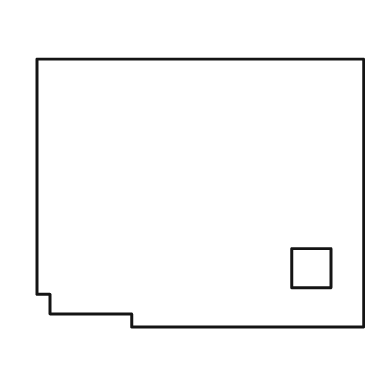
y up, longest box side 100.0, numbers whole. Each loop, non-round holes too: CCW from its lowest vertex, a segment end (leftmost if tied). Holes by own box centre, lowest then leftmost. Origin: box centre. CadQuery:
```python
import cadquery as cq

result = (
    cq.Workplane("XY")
    .moveTo(-21.0, -41.0)
    .lineTo(50.0, -41.0)
    .lineTo(50.0, 41.0)
    .lineTo(-50.0, 41.0)
    .lineTo(-50.0, -31.0)
    .lineTo(-46.0, -31.0)
    .lineTo(-46.0, -37.0)
    .lineTo(-21.0, -37.0)
    .close()
    .moveTo(28.0, -29.0)
    .lineTo(40.0, -29.0)
    .lineTo(40.0, -17.0)
    .lineTo(28.0, -17.0)
    .close()
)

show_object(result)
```